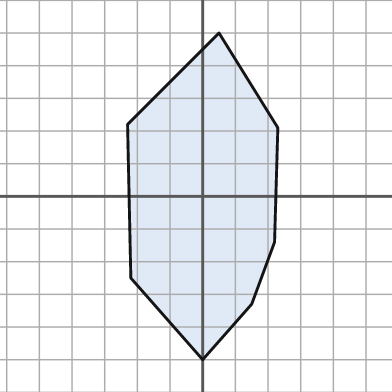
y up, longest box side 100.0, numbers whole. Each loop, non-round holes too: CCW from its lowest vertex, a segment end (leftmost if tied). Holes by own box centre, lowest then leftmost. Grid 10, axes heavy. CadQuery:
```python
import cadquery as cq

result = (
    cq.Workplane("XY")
    .moveTo(0.0, -50.0)
    .lineTo(15.0, -33.0)
    .lineTo(22.0, -14.0)
    .lineTo(23.0, 21.0)
    .lineTo(5.0, 50.0)
    .lineTo(-23.0, 22.0)
    .lineTo(-22.0, -25.0)
    .close()
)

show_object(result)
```